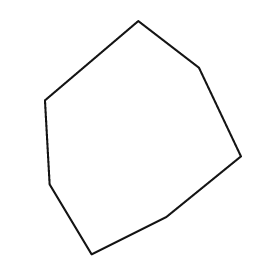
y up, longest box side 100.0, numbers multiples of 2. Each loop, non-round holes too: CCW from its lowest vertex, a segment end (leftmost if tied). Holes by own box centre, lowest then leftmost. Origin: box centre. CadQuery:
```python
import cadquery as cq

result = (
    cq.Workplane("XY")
    .moveTo(-22.0, -50.0)
    .lineTo(10.0, -34.0)
    .lineTo(42.0, -8.0)
    .lineTo(24.0, 30.0)
    .lineTo(-2.0, 50.0)
    .lineTo(-42.0, 16.0)
    .lineTo(-40.0, -20.0)
    .close()
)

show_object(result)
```